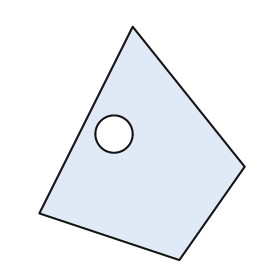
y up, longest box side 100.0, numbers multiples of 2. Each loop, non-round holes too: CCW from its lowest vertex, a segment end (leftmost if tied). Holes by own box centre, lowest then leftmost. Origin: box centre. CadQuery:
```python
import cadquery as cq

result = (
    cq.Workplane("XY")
    .moveTo(16.0, -50.0)
    .lineTo(44.0, -10.0)
    .lineTo(-4.0, 50.0)
    .lineTo(-44.0, -30.0)
    .close()
    .moveTo(-12.0, 4.0)
    .circle(8.0)
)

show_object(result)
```